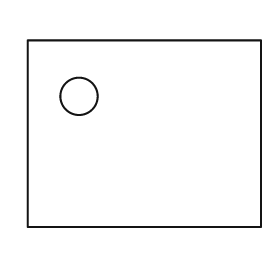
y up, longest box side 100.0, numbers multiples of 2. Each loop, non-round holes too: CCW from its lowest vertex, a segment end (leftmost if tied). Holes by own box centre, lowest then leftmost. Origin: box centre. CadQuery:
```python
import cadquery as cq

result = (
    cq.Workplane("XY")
    .moveTo(-50.0, -40.0)
    .lineTo(50.0, -40.0)
    .lineTo(50.0, 40.0)
    .lineTo(-50.0, 40.0)
    .close()
    .moveTo(-28.0, 16.0)
    .circle(8.0)
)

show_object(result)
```